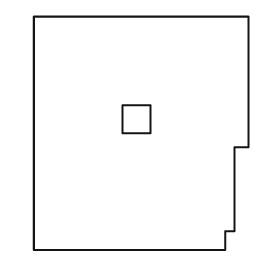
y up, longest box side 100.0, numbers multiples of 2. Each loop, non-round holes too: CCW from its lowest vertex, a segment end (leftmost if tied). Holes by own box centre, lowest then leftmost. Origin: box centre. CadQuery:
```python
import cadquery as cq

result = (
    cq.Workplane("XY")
    .moveTo(-46.0, -50.0)
    .lineTo(36.0, -50.0)
    .lineTo(36.0, -42.0)
    .lineTo(40.0, -42.0)
    .lineTo(40.0, -6.0)
    .lineTo(46.0, -6.0)
    .lineTo(46.0, 50.0)
    .lineTo(-46.0, 50.0)
    .close()
    .moveTo(-8.0, 0.0)
    .lineTo(4.0, 0.0)
    .lineTo(4.0, 12.0)
    .lineTo(-8.0, 12.0)
    .close()
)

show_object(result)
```